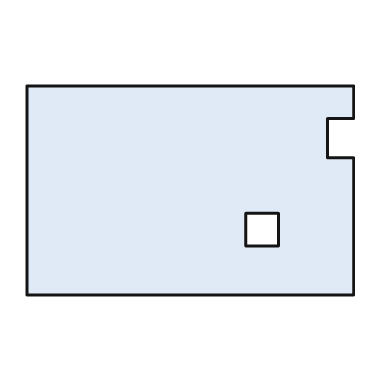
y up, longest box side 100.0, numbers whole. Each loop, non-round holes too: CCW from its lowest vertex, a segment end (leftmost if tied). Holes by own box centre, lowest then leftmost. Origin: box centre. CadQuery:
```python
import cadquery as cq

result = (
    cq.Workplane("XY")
    .moveTo(-50.0, -32.0)
    .lineTo(50.0, -32.0)
    .lineTo(50.0, 10.0)
    .lineTo(42.0, 10.0)
    .lineTo(42.0, 22.0)
    .lineTo(50.0, 22.0)
    .lineTo(50.0, 32.0)
    .lineTo(-50.0, 32.0)
    .close()
    .moveTo(17.0, -17.0)
    .lineTo(27.0, -17.0)
    .lineTo(27.0, -7.0)
    .lineTo(17.0, -7.0)
    .close()
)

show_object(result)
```